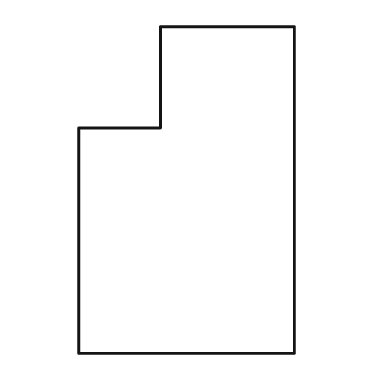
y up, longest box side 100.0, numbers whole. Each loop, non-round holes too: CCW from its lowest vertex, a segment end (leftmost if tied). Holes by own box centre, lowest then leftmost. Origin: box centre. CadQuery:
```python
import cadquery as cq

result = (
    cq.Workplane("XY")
    .moveTo(-33.0, -50.0)
    .lineTo(33.0, -50.0)
    .lineTo(33.0, 50.0)
    .lineTo(-8.0, 50.0)
    .lineTo(-8.0, 19.0)
    .lineTo(-33.0, 19.0)
    .close()
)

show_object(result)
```